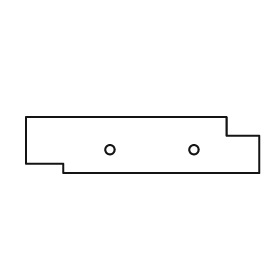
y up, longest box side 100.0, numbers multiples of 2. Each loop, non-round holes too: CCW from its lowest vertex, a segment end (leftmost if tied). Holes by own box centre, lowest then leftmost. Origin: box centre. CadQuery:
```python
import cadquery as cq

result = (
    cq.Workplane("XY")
    .moveTo(-34.0, -12.0)
    .lineTo(50.0, -12.0)
    .lineTo(50.0, 4.0)
    .lineTo(36.0, 4.0)
    .lineTo(36.0, 12.0)
    .lineTo(-50.0, 12.0)
    .lineTo(-50.0, -8.0)
    .lineTo(-34.0, -8.0)
    .close()
    .moveTo(-14.0, -2.0)
    .circle(2.0)
    .moveTo(22.0, -2.0)
    .circle(2.0)
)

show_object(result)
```